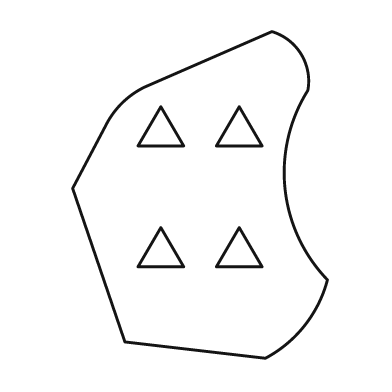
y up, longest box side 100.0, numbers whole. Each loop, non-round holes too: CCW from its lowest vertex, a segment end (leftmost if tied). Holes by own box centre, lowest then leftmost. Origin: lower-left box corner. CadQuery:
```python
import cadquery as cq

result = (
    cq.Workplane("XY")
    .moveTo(59.0, 0.0)
    .threePointArc((71.0, 10.0), (78.0, 24.0))
    .threePointArc((65.0, 52.0), (72.0, 82.0))
    .threePointArc((70.0, 93.0), (61.0, 100.0))
    .lineTo(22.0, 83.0)
    .threePointArc((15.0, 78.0), (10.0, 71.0))
    .lineTo(0.0, 52.0)
    .lineTo(16.0, 5.0)
    .close()
    .moveTo(20.0, 28.0)
    .lineTo(34.0, 28.0)
    .lineTo(27.0, 40.0)
    .close()
    .moveTo(44.0, 28.0)
    .lineTo(58.0, 28.0)
    .lineTo(51.0, 40.0)
    .close()
    .moveTo(20.0, 65.0)
    .lineTo(34.0, 65.0)
    .lineTo(27.0, 77.0)
    .close()
    .moveTo(44.0, 65.0)
    .lineTo(58.0, 65.0)
    .lineTo(51.0, 77.0)
    .close()
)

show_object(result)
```